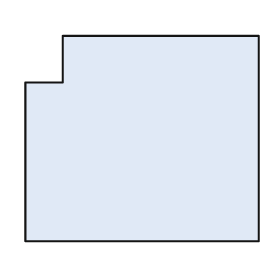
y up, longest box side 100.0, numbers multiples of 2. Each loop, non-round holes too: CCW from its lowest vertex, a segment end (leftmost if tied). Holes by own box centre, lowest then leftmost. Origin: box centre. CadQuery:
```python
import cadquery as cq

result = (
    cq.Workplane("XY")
    .moveTo(-50.0, -44.0)
    .lineTo(50.0, -44.0)
    .lineTo(50.0, 44.0)
    .lineTo(-34.0, 44.0)
    .lineTo(-34.0, 24.0)
    .lineTo(-50.0, 24.0)
    .close()
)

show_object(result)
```